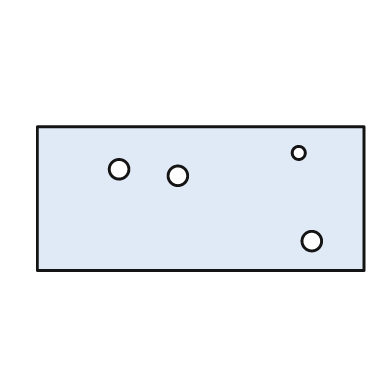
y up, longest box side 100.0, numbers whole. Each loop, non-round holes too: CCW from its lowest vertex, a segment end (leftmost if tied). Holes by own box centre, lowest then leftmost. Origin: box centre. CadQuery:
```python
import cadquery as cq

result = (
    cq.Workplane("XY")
    .moveTo(-50.0, -22.0)
    .lineTo(50.0, -22.0)
    .lineTo(50.0, 22.0)
    .lineTo(-50.0, 22.0)
    .close()
    .moveTo(34.0, -13.0)
    .circle(3.0)
    .moveTo(-7.0, 7.0)
    .circle(3.0)
    .moveTo(-25.0, 9.0)
    .circle(3.0)
    .moveTo(30.0, 14.0)
    .circle(2.0)
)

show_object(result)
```